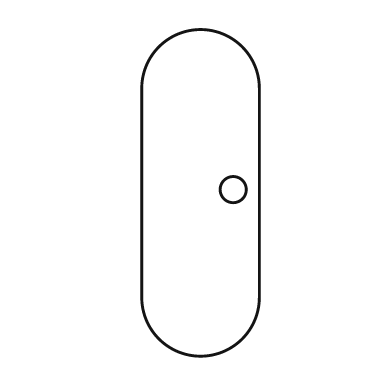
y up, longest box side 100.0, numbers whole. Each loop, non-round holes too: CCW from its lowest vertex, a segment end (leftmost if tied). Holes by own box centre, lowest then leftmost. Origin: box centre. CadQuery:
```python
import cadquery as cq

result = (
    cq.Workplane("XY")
    .moveTo(-18.0, -32.0)
    .threePointArc((0.0, -50.0), (18.0, -32.0))
    .lineTo(18.0, 32.0)
    .threePointArc((0.0, 50.0), (-18.0, 32.0))
    .close()
    .moveTo(10.0, 1.0)
    .circle(4.0)
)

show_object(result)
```